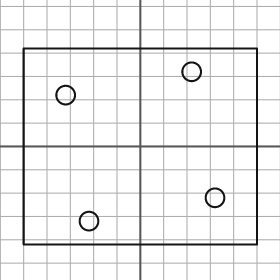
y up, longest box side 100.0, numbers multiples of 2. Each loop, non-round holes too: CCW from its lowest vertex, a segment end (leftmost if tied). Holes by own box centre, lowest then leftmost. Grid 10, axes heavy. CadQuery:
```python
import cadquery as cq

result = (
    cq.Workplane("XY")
    .moveTo(-50.0, -42.0)
    .lineTo(50.0, -42.0)
    .lineTo(50.0, 42.0)
    .lineTo(-50.0, 42.0)
    .close()
    .moveTo(-22.0, -32.0)
    .circle(4.0)
    .moveTo(32.0, -22.0)
    .circle(4.0)
    .moveTo(-32.0, 22.0)
    .circle(4.0)
    .moveTo(22.0, 32.0)
    .circle(4.0)
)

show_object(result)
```